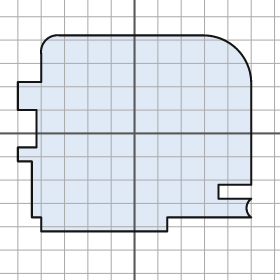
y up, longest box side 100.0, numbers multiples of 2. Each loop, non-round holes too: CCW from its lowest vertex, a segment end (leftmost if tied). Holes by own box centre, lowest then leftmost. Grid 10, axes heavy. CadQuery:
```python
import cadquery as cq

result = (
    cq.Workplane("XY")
    .moveTo(-40.0, -42.0)
    .lineTo(14.0, -42.0)
    .lineTo(14.0, -36.0)
    .lineTo(50.0, -36.0)
    .threePointArc((48.0, -32.0), (50.0, -28.0))
    .lineTo(36.0, -28.0)
    .lineTo(36.0, -22.0)
    .lineTo(50.0, -22.0)
    .lineTo(50.0, 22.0)
    .threePointArc((44.0, 36.0), (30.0, 42.0))
    .lineTo(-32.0, 42.0)
    .threePointArc((-38.0, 40.0), (-40.0, 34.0))
    .lineTo(-40.0, 22.0)
    .lineTo(-50.0, 22.0)
    .lineTo(-50.0, 10.0)
    .lineTo(-42.0, 10.0)
    .lineTo(-42.0, -6.0)
    .lineTo(-50.0, -6.0)
    .lineTo(-50.0, -12.0)
    .lineTo(-44.0, -12.0)
    .lineTo(-44.0, -36.0)
    .lineTo(-40.0, -36.0)
    .close()
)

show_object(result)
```